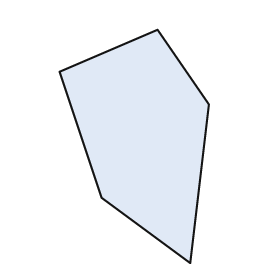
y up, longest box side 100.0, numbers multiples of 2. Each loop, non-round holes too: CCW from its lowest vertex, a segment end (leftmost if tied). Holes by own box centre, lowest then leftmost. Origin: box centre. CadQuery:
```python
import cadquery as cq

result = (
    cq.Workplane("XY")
    .moveTo(24.0, -50.0)
    .lineTo(32.0, 18.0)
    .lineTo(10.0, 50.0)
    .lineTo(-32.0, 32.0)
    .lineTo(-14.0, -22.0)
    .close()
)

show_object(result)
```